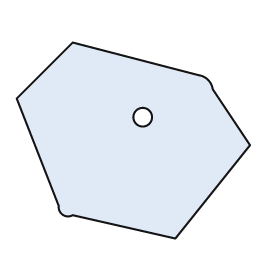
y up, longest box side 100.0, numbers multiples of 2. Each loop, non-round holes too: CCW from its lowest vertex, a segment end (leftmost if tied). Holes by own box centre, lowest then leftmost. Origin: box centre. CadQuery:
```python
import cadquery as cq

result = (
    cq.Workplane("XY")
    .moveTo(18.0, -42.0)
    .lineTo(50.0, -2.0)
    .lineTo(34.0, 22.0)
    .threePointArc((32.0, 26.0), (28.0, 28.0))
    .lineTo(-26.0, 42.0)
    .lineTo(-50.0, 18.0)
    .lineTo(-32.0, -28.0)
    .threePointArc((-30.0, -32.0), (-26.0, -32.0))
    .close()
    .moveTo(4.0, 10.0)
    .circle(4.0)
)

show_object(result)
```